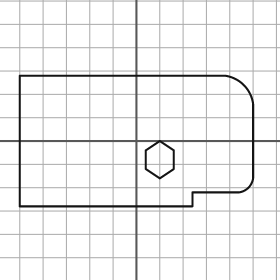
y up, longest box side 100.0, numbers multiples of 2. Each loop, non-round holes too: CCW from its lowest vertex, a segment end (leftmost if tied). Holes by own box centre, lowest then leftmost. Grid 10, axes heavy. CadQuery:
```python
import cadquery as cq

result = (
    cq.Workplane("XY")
    .moveTo(-50.0, -28.0)
    .lineTo(24.0, -28.0)
    .lineTo(24.0, -22.0)
    .lineTo(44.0, -22.0)
    .threePointArc((48.0, -20.0), (50.0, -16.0))
    .lineTo(50.0, 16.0)
    .threePointArc((46.0, 24.0), (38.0, 28.0))
    .lineTo(-50.0, 28.0)
    .close()
    .moveTo(10.0, -16.0)
    .lineTo(16.0, -12.0)
    .lineTo(16.0, -4.0)
    .lineTo(10.0, 0.0)
    .lineTo(4.0, -4.0)
    .lineTo(4.0, -12.0)
    .close()
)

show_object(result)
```